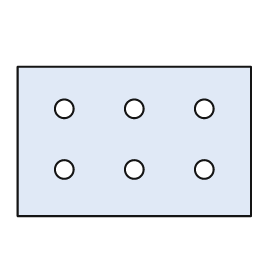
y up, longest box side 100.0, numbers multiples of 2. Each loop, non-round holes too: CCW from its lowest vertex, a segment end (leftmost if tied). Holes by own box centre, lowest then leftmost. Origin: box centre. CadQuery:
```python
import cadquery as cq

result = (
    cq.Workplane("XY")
    .moveTo(-50.0, -32.0)
    .lineTo(50.0, -32.0)
    .lineTo(50.0, 32.0)
    .lineTo(-50.0, 32.0)
    .close()
    .moveTo(-30.0, -12.0)
    .circle(4.0)
    .moveTo(0.0, -12.0)
    .circle(4.0)
    .moveTo(30.0, -12.0)
    .circle(4.0)
    .moveTo(-30.0, 14.0)
    .circle(4.0)
    .moveTo(0.0, 14.0)
    .circle(4.0)
    .moveTo(30.0, 14.0)
    .circle(4.0)
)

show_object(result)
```